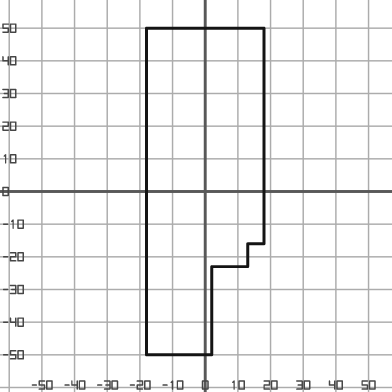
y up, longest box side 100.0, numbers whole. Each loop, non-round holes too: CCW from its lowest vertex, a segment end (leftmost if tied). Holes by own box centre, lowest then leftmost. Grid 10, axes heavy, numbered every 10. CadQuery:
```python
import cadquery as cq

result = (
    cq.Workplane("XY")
    .moveTo(-18.0, -50.0)
    .lineTo(2.0, -50.0)
    .lineTo(2.0, -23.0)
    .lineTo(13.0, -23.0)
    .lineTo(13.0, -16.0)
    .lineTo(18.0, -16.0)
    .lineTo(18.0, 50.0)
    .lineTo(-18.0, 50.0)
    .close()
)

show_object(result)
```